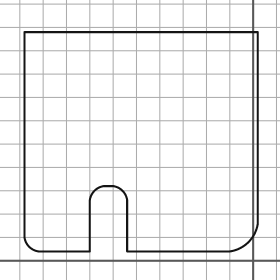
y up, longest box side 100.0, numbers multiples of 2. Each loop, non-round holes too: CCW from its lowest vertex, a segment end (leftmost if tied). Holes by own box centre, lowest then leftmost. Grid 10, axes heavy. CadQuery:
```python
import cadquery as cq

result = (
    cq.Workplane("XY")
    .moveTo(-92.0, 4.0)
    .lineTo(-70.0, 4.0)
    .lineTo(-70.0, 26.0)
    .threePointArc((-68.0, 30.0), (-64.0, 32.0))
    .lineTo(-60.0, 32.0)
    .threePointArc((-56.0, 30.0), (-54.0, 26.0))
    .lineTo(-54.0, 4.0)
    .lineTo(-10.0, 4.0)
    .threePointArc((-2.0, 8.0), (2.0, 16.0))
    .lineTo(2.0, 98.0)
    .lineTo(-98.0, 98.0)
    .lineTo(-98.0, 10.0)
    .threePointArc((-96.0, 6.0), (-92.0, 4.0))
    .close()
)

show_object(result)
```